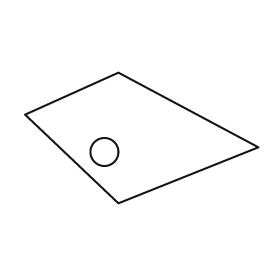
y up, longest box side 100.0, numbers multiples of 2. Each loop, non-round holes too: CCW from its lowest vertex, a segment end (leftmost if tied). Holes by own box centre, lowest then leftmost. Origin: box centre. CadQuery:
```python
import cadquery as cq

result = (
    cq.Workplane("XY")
    .moveTo(-10.0, -28.0)
    .lineTo(50.0, -4.0)
    .lineTo(-10.0, 28.0)
    .lineTo(-50.0, 10.0)
    .close()
    .moveTo(-16.0, -6.0)
    .circle(6.0)
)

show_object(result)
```